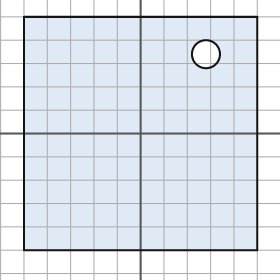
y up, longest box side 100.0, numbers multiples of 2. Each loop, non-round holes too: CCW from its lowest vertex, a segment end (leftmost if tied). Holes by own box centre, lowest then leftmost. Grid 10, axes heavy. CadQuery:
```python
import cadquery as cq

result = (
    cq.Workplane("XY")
    .moveTo(-50.0, -50.0)
    .lineTo(50.0, -50.0)
    .lineTo(50.0, 50.0)
    .lineTo(-50.0, 50.0)
    .close()
    .moveTo(28.0, 34.0)
    .circle(6.0)
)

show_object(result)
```